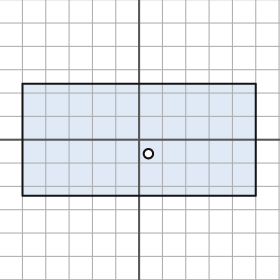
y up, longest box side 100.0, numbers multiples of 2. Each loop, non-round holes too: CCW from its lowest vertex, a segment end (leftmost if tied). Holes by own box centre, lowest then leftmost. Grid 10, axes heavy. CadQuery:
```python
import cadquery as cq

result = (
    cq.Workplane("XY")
    .moveTo(-50.0, -24.0)
    .lineTo(50.0, -24.0)
    .lineTo(50.0, 24.0)
    .lineTo(-50.0, 24.0)
    .close()
    .moveTo(4.0, -6.0)
    .circle(2.0)
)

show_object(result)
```